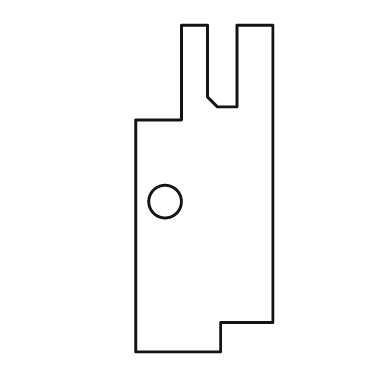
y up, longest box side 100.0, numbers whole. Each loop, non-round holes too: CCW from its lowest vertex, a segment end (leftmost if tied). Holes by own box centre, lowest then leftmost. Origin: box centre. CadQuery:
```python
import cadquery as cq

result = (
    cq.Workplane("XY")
    .moveTo(-21.0, -50.0)
    .lineTo(5.0, -50.0)
    .lineTo(5.0, -41.0)
    .lineTo(21.0, -41.0)
    .lineTo(21.0, 50.0)
    .lineTo(10.0, 50.0)
    .lineTo(10.0, 25.0)
    .lineTo(4.0, 25.0)
    .lineTo(1.0, 28.0)
    .lineTo(1.0, 50.0)
    .lineTo(-7.0, 50.0)
    .lineTo(-7.0, 21.0)
    .lineTo(-21.0, 21.0)
    .close()
    .moveTo(-12.0, -4.0)
    .circle(5.0)
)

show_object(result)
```